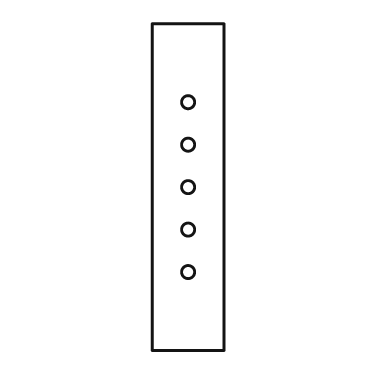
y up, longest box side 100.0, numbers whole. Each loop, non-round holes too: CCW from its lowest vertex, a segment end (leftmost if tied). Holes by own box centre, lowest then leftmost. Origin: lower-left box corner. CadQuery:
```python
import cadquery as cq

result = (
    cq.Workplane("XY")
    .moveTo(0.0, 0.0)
    .lineTo(22.0, 0.0)
    .lineTo(22.0, 100.0)
    .lineTo(0.0, 100.0)
    .close()
    .moveTo(11.0, 24.0)
    .circle(2.0)
    .moveTo(11.0, 37.0)
    .circle(2.0)
    .moveTo(11.0, 50.0)
    .circle(2.0)
    .moveTo(11.0, 63.0)
    .circle(2.0)
    .moveTo(11.0, 76.0)
    .circle(2.0)
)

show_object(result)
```